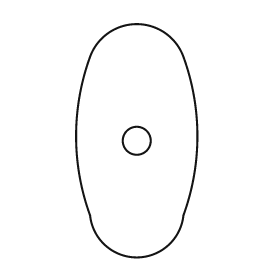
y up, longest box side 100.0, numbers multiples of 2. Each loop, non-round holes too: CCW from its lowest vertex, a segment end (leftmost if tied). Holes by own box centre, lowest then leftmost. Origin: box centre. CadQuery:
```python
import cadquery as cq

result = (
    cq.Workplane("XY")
    .moveTo(-20.0, -32.0)
    .threePointArc((0.0, -50.0), (20.0, -32.0))
    .threePointArc((26.0, 2.0), (20.0, 36.0))
    .threePointArc((0.0, 50.0), (-20.0, 36.0))
    .threePointArc((-26.0, 2.0), (-20.0, -32.0))
    .close()
    .moveTo(0.0, 0.0)
    .circle(6.0)
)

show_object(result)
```